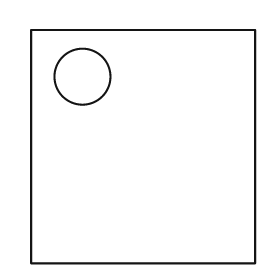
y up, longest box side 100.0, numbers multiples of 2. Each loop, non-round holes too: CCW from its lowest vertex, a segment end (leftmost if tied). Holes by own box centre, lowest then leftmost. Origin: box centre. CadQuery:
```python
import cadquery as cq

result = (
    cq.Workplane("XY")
    .moveTo(-48.0, -50.0)
    .lineTo(48.0, -50.0)
    .lineTo(48.0, 50.0)
    .lineTo(-48.0, 50.0)
    .close()
    .moveTo(-26.0, 30.0)
    .circle(12.0)
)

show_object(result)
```